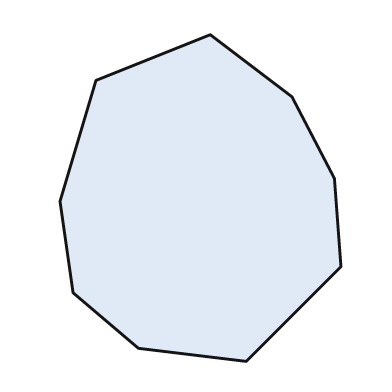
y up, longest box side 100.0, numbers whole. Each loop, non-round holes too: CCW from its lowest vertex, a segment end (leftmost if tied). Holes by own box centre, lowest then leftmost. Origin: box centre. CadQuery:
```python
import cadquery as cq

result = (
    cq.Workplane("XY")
    .moveTo(14.0, -50.0)
    .lineTo(43.0, -21.0)
    .lineTo(41.0, 6.0)
    .lineTo(28.0, 31.0)
    .lineTo(3.0, 50.0)
    .lineTo(-32.0, 36.0)
    .lineTo(-43.0, -1.0)
    .lineTo(-39.0, -29.0)
    .lineTo(-19.0, -46.0)
    .close()
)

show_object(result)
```